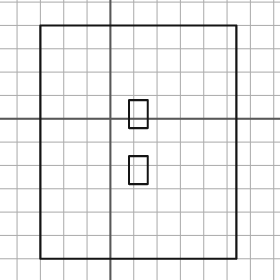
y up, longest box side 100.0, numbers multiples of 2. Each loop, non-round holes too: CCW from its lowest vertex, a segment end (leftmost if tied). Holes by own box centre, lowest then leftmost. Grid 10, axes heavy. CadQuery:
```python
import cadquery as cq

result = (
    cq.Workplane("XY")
    .moveTo(-30.0, -60.0)
    .lineTo(54.0, -60.0)
    .lineTo(54.0, 40.0)
    .lineTo(-30.0, 40.0)
    .close()
    .moveTo(8.0, -28.0)
    .lineTo(16.0, -28.0)
    .lineTo(16.0, -16.0)
    .lineTo(8.0, -16.0)
    .close()
    .moveTo(8.0, -4.0)
    .lineTo(16.0, -4.0)
    .lineTo(16.0, 8.0)
    .lineTo(8.0, 8.0)
    .close()
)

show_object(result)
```